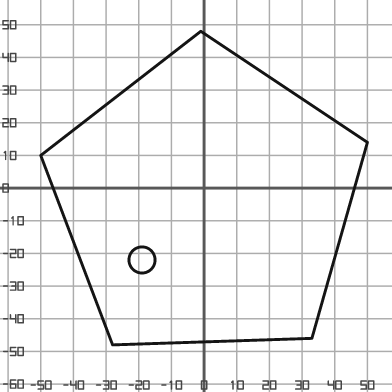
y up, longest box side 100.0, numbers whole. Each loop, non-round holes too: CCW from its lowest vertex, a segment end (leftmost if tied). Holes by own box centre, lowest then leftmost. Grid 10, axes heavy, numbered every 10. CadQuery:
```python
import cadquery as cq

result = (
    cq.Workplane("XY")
    .moveTo(-28.0, -48.0)
    .lineTo(33.0, -46.0)
    .lineTo(50.0, 14.0)
    .lineTo(-1.0, 48.0)
    .lineTo(-50.0, 10.0)
    .close()
    .moveTo(-19.0, -22.0)
    .circle(4.0)
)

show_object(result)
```